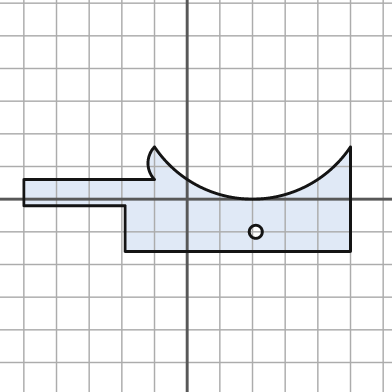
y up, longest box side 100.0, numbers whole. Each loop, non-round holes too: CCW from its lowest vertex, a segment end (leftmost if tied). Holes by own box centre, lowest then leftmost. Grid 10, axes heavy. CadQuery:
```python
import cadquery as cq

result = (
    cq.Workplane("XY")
    .moveTo(-19.0, -16.0)
    .lineTo(50.0, -16.0)
    .lineTo(50.0, 16.0)
    .threePointArc((20.0, 0.0), (-10.0, 16.0))
    .threePointArc((-12.0, 11.0), (-10.0, 6.0))
    .lineTo(-50.0, 6.0)
    .lineTo(-50.0, -2.0)
    .lineTo(-19.0, -2.0)
    .close()
    .moveTo(21.0, -10.0)
    .circle(2.0)
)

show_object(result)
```